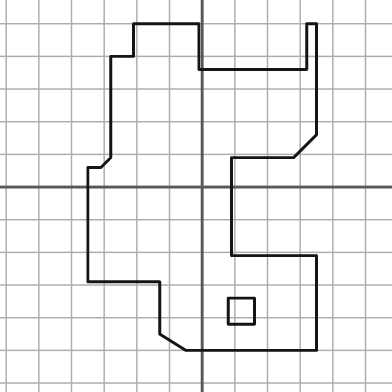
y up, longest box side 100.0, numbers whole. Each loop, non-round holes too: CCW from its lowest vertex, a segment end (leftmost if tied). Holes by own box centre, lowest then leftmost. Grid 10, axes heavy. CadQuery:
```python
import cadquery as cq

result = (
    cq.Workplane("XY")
    .moveTo(-5.0, -50.0)
    .lineTo(35.0, -50.0)
    .lineTo(35.0, -21.0)
    .lineTo(9.0, -21.0)
    .lineTo(9.0, 9.0)
    .lineTo(28.0, 9.0)
    .lineTo(35.0, 16.0)
    .lineTo(35.0, 50.0)
    .lineTo(32.0, 50.0)
    .lineTo(32.0, 36.0)
    .lineTo(-1.0, 36.0)
    .lineTo(-1.0, 50.0)
    .lineTo(-21.0, 50.0)
    .lineTo(-21.0, 40.0)
    .lineTo(-28.0, 40.0)
    .lineTo(-28.0, 9.0)
    .lineTo(-31.0, 6.0)
    .lineTo(-35.0, 6.0)
    .lineTo(-35.0, -29.0)
    .lineTo(-13.0, -29.0)
    .lineTo(-13.0, -45.0)
    .close()
    .moveTo(8.0, -42.0)
    .lineTo(16.0, -42.0)
    .lineTo(16.0, -34.0)
    .lineTo(8.0, -34.0)
    .close()
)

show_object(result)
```